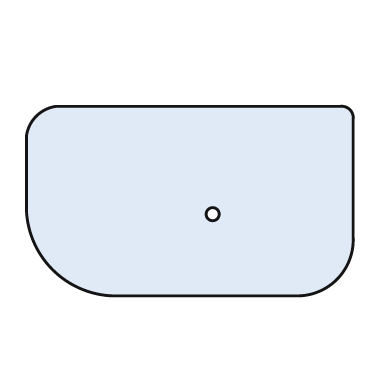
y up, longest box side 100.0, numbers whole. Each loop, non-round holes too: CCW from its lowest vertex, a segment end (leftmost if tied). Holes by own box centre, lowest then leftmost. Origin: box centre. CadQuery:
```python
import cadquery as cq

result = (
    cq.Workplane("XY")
    .moveTo(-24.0, -29.0)
    .lineTo(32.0, -29.0)
    .threePointArc((45.0, -24.0), (50.0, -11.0))
    .lineTo(50.0, 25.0)
    .threePointArc((49.0, 28.0), (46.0, 29.0))
    .lineTo(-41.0, 29.0)
    .threePointArc((-47.0, 26.0), (-50.0, 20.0))
    .lineTo(-50.0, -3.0)
    .threePointArc((-42.0, -21.0), (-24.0, -29.0))
    .close()
    .moveTo(7.0, -4.0)
    .circle(2.0)
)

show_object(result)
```